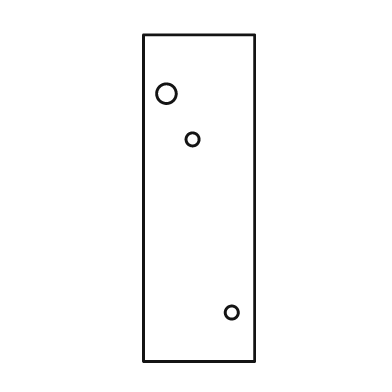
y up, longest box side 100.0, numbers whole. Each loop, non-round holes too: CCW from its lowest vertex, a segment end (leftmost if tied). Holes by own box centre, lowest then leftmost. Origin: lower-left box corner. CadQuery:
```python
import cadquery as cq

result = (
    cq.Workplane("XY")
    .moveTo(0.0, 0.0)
    .lineTo(34.0, 0.0)
    .lineTo(34.0, 100.0)
    .lineTo(0.0, 100.0)
    .close()
    .moveTo(27.0, 15.0)
    .circle(2.0)
    .moveTo(15.0, 68.0)
    .circle(2.0)
    .moveTo(7.0, 82.0)
    .circle(3.0)
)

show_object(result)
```